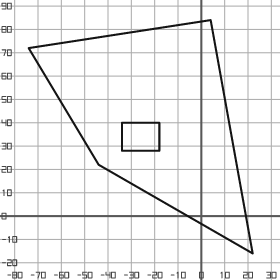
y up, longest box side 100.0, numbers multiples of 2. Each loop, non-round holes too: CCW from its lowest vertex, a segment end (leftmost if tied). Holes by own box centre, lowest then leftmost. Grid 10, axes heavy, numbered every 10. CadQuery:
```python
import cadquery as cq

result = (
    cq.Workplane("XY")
    .moveTo(22.0, -16.0)
    .lineTo(4.0, 84.0)
    .lineTo(-74.0, 72.0)
    .lineTo(-44.0, 22.0)
    .close()
    .moveTo(-34.0, 28.0)
    .lineTo(-18.0, 28.0)
    .lineTo(-18.0, 40.0)
    .lineTo(-34.0, 40.0)
    .close()
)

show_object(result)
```